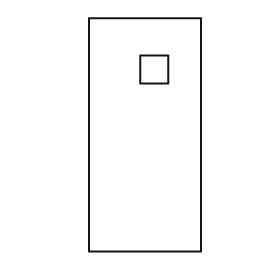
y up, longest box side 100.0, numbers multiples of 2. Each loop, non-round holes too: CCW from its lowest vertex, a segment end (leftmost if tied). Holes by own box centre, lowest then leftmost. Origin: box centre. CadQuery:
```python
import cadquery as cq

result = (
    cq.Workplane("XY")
    .moveTo(-24.0, -50.0)
    .lineTo(24.0, -50.0)
    .lineTo(24.0, 50.0)
    .lineTo(-24.0, 50.0)
    .close()
    .moveTo(-2.0, 22.0)
    .lineTo(10.0, 22.0)
    .lineTo(10.0, 34.0)
    .lineTo(-2.0, 34.0)
    .close()
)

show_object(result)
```